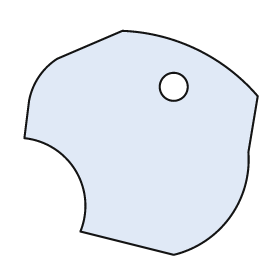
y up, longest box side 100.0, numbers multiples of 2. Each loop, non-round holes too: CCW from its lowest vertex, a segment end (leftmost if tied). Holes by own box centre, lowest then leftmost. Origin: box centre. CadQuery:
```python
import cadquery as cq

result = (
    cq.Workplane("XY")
    .moveTo(14.0, -48.0)
    .threePointArc((38.0, -32.0), (46.0, -4.0))
    .lineTo(50.0, 20.0)
    .threePointArc((24.0, 40.0), (-8.0, 48.0))
    .lineTo(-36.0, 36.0)
    .threePointArc((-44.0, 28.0), (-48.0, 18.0))
    .lineTo(-50.0, 2.0)
    .threePointArc((-28.0, -12.0), (-26.0, -38.0))
    .close()
    .moveTo(14.0, 24.0)
    .circle(6.0)
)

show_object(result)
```